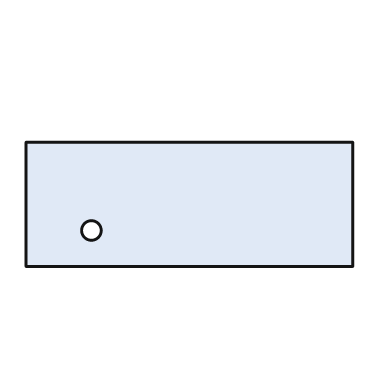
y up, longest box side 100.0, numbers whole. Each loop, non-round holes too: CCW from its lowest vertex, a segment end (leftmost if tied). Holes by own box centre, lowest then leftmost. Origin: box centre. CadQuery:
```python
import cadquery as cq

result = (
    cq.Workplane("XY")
    .moveTo(-50.0, -19.0)
    .lineTo(50.0, -19.0)
    .lineTo(50.0, 19.0)
    .lineTo(-50.0, 19.0)
    .close()
    .moveTo(-30.0, -8.0)
    .circle(3.0)
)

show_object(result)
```